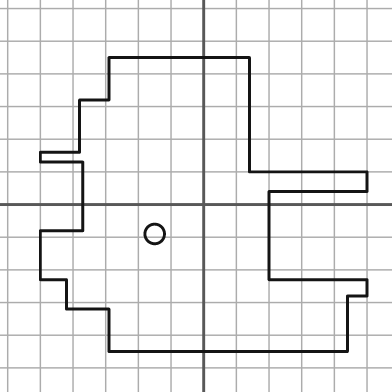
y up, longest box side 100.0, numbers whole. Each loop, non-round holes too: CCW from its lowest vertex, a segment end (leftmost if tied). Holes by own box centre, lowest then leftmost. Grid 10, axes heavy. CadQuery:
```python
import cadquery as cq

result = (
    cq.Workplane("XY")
    .moveTo(-29.0, -45.0)
    .lineTo(44.0, -45.0)
    .lineTo(44.0, -28.0)
    .lineTo(50.0, -28.0)
    .lineTo(50.0, -23.0)
    .lineTo(20.0, -23.0)
    .lineTo(20.0, 4.0)
    .lineTo(50.0, 4.0)
    .lineTo(50.0, 10.0)
    .lineTo(14.0, 10.0)
    .lineTo(14.0, 45.0)
    .lineTo(-29.0, 45.0)
    .lineTo(-29.0, 32.0)
    .lineTo(-38.0, 32.0)
    .lineTo(-38.0, 16.0)
    .lineTo(-50.0, 16.0)
    .lineTo(-50.0, 13.0)
    .lineTo(-37.0, 13.0)
    .lineTo(-37.0, -8.0)
    .lineTo(-50.0, -8.0)
    .lineTo(-50.0, -23.0)
    .lineTo(-42.0, -23.0)
    .lineTo(-42.0, -32.0)
    .lineTo(-29.0, -32.0)
    .close()
    .moveTo(-15.0, -9.0)
    .circle(3.0)
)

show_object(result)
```